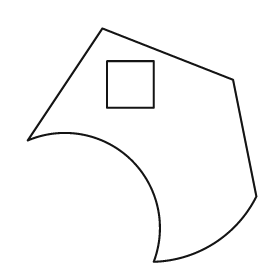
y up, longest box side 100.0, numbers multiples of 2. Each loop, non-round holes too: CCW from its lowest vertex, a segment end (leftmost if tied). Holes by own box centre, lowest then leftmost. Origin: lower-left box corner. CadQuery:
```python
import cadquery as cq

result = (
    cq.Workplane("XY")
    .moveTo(54.0, 0.0)
    .threePointArc((80.0, 8.0), (98.0, 28.0))
    .lineTo(88.0, 78.0)
    .lineTo(32.0, 100.0)
    .lineTo(0.0, 52.0)
    .threePointArc((44.0, 44.0), (54.0, 0.0))
    .close()
    .moveTo(34.0, 66.0)
    .lineTo(54.0, 66.0)
    .lineTo(54.0, 86.0)
    .lineTo(34.0, 86.0)
    .close()
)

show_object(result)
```